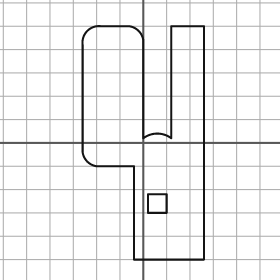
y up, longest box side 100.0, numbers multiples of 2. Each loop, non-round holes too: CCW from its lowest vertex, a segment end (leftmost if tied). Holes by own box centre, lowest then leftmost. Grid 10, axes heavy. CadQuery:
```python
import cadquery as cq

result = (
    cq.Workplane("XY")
    .moveTo(-4.0, -50.0)
    .lineTo(26.0, -50.0)
    .lineTo(26.0, 50.0)
    .lineTo(12.0, 50.0)
    .lineTo(12.0, 2.0)
    .threePointArc((6.0, 4.0), (0.0, 2.0))
    .lineTo(0.0, 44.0)
    .threePointArc((-2.0, 48.0), (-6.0, 50.0))
    .lineTo(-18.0, 50.0)
    .threePointArc((-24.0, 48.0), (-26.0, 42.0))
    .lineTo(-26.0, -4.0)
    .threePointArc((-24.0, -8.0), (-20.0, -10.0))
    .lineTo(-4.0, -10.0)
    .close()
    .moveTo(2.0, -30.0)
    .lineTo(10.0, -30.0)
    .lineTo(10.0, -22.0)
    .lineTo(2.0, -22.0)
    .close()
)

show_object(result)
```